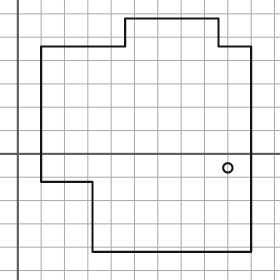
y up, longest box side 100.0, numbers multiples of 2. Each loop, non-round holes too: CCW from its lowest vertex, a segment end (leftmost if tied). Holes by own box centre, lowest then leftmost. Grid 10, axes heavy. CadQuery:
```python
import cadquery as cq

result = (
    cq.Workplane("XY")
    .moveTo(32.0, -42.0)
    .lineTo(100.0, -42.0)
    .lineTo(100.0, 46.0)
    .lineTo(86.0, 46.0)
    .lineTo(86.0, 58.0)
    .lineTo(46.0, 58.0)
    .lineTo(46.0, 46.0)
    .lineTo(10.0, 46.0)
    .lineTo(10.0, -12.0)
    .lineTo(32.0, -12.0)
    .close()
    .moveTo(90.0, -6.0)
    .circle(2.0)
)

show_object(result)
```